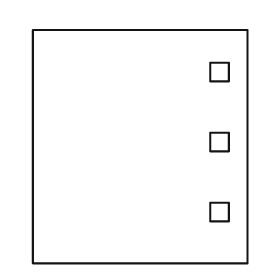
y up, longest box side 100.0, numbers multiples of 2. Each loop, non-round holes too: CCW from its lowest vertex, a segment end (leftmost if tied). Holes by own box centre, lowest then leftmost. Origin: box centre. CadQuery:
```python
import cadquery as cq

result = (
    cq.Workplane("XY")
    .moveTo(-46.0, -50.0)
    .lineTo(46.0, -50.0)
    .lineTo(46.0, 50.0)
    .lineTo(-46.0, 50.0)
    .close()
    .moveTo(30.0, -32.0)
    .lineTo(38.0, -32.0)
    .lineTo(38.0, -24.0)
    .lineTo(30.0, -24.0)
    .close()
    .moveTo(30.0, -2.0)
    .lineTo(38.0, -2.0)
    .lineTo(38.0, 6.0)
    .lineTo(30.0, 6.0)
    .close()
    .moveTo(30.0, 28.0)
    .lineTo(38.0, 28.0)
    .lineTo(38.0, 36.0)
    .lineTo(30.0, 36.0)
    .close()
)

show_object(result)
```